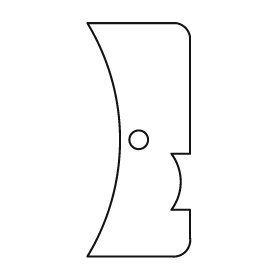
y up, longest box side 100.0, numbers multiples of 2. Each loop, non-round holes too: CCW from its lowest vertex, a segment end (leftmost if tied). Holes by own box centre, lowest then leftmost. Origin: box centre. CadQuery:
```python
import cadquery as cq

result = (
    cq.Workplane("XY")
    .moveTo(-22.0, -50.0)
    .lineTo(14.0, -50.0)
    .threePointArc((20.0, -48.0), (22.0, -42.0))
    .lineTo(22.0, -30.0)
    .lineTo(14.0, -30.0)
    .threePointArc((18.0, -18.0), (14.0, -6.0))
    .lineTo(22.0, -6.0)
    .lineTo(22.0, 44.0)
    .threePointArc((20.0, 48.0), (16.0, 50.0))
    .lineTo(-22.0, 50.0)
    .threePointArc((-8.0, 0.0), (-22.0, -50.0))
    .close()
    .moveTo(0.0, 0.0)
    .circle(4.0)
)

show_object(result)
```